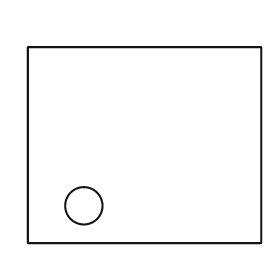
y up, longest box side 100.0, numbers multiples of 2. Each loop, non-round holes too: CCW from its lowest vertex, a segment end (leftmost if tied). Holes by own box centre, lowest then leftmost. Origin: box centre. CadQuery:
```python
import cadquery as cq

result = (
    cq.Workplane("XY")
    .moveTo(-50.0, -42.0)
    .lineTo(50.0, -42.0)
    .lineTo(50.0, 42.0)
    .lineTo(-50.0, 42.0)
    .close()
    .moveTo(-26.0, -26.0)
    .circle(8.0)
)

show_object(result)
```